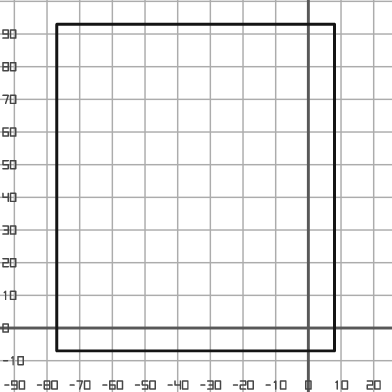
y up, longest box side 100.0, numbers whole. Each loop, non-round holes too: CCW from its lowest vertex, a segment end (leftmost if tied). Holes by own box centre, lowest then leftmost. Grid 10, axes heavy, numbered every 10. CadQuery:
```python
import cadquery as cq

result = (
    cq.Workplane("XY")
    .moveTo(-77.0, -7.0)
    .lineTo(8.0, -7.0)
    .lineTo(8.0, 93.0)
    .lineTo(-77.0, 93.0)
    .close()
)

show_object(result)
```